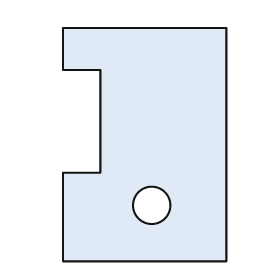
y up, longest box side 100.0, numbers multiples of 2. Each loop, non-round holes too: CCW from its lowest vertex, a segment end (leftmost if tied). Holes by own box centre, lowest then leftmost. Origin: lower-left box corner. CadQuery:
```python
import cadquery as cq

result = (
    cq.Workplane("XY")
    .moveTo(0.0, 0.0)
    .lineTo(70.0, 0.0)
    .lineTo(70.0, 100.0)
    .lineTo(0.0, 100.0)
    .lineTo(0.0, 82.0)
    .lineTo(16.0, 82.0)
    .lineTo(16.0, 38.0)
    .lineTo(0.0, 38.0)
    .close()
    .moveTo(38.0, 24.0)
    .circle(8.0)
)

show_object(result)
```